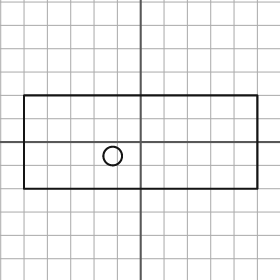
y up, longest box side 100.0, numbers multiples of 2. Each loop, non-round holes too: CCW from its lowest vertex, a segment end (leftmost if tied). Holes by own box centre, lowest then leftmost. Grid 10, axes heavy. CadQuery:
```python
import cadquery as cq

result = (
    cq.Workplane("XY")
    .moveTo(-50.0, -20.0)
    .lineTo(50.0, -20.0)
    .lineTo(50.0, 20.0)
    .lineTo(-50.0, 20.0)
    .close()
    .moveTo(-12.0, -6.0)
    .circle(4.0)
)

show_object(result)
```